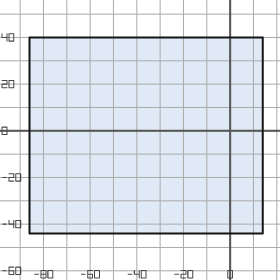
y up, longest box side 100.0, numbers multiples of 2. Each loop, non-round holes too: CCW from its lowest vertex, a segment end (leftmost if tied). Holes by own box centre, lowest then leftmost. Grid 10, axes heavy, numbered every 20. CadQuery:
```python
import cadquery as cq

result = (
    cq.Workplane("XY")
    .moveTo(-86.0, -44.0)
    .lineTo(14.0, -44.0)
    .lineTo(14.0, 40.0)
    .lineTo(-86.0, 40.0)
    .close()
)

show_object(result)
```